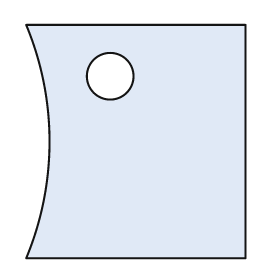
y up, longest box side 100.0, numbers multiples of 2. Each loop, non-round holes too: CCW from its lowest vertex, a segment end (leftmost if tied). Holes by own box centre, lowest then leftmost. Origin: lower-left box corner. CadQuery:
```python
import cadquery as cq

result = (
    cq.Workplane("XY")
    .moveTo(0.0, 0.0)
    .lineTo(94.0, 0.0)
    .lineTo(94.0, 100.0)
    .lineTo(0.0, 100.0)
    .threePointArc((10.0, 50.0), (0.0, 0.0))
    .close()
    .moveTo(36.0, 78.0)
    .circle(10.0)
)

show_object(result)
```